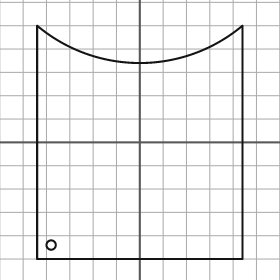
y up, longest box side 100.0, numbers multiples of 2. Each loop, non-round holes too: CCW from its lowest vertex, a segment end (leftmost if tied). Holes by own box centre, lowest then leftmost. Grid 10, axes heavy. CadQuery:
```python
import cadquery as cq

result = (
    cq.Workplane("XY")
    .moveTo(-44.0, -50.0)
    .lineTo(44.0, -50.0)
    .lineTo(44.0, 50.0)
    .threePointArc((0.0, 34.0), (-44.0, 50.0))
    .close()
    .moveTo(-38.0, -44.0)
    .circle(2.0)
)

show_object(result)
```